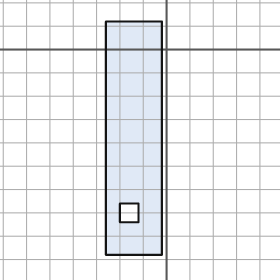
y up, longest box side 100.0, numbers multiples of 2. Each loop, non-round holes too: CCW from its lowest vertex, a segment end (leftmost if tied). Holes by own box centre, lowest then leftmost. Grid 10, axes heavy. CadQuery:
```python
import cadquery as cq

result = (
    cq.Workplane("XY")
    .moveTo(-26.0, -88.0)
    .lineTo(-2.0, -88.0)
    .lineTo(-2.0, 12.0)
    .lineTo(-26.0, 12.0)
    .close()
    .moveTo(-20.0, -74.0)
    .lineTo(-12.0, -74.0)
    .lineTo(-12.0, -66.0)
    .lineTo(-20.0, -66.0)
    .close()
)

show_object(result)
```